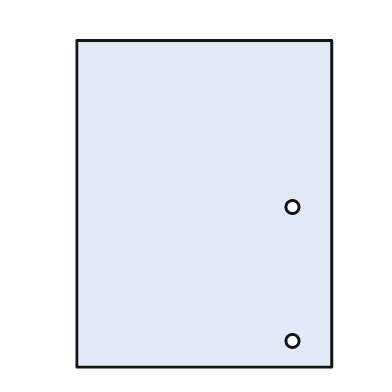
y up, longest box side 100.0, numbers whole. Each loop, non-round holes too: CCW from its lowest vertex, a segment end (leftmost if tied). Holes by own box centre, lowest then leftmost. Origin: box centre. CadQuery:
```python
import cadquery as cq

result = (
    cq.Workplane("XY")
    .moveTo(-39.0, -50.0)
    .lineTo(39.0, -50.0)
    .lineTo(39.0, 50.0)
    .lineTo(-39.0, 50.0)
    .close()
    .moveTo(27.0, -42.0)
    .circle(2.0)
    .moveTo(27.0, -1.0)
    .circle(2.0)
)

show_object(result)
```